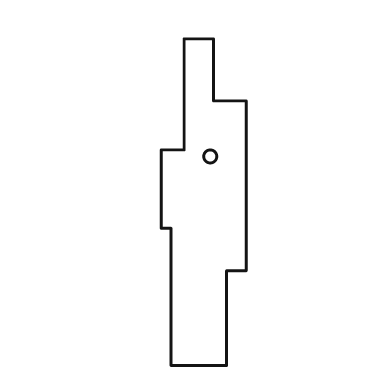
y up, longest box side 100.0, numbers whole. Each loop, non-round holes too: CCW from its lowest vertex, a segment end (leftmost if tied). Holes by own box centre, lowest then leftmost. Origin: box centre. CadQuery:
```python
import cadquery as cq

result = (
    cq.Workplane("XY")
    .moveTo(-10.0, -50.0)
    .lineTo(7.0, -50.0)
    .lineTo(7.0, -21.0)
    .lineTo(13.0, -21.0)
    .lineTo(13.0, 31.0)
    .lineTo(3.0, 31.0)
    .lineTo(3.0, 50.0)
    .lineTo(-6.0, 50.0)
    .lineTo(-6.0, 16.0)
    .lineTo(-13.0, 16.0)
    .lineTo(-13.0, -8.0)
    .lineTo(-10.0, -8.0)
    .close()
    .moveTo(2.0, 14.0)
    .circle(2.0)
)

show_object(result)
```